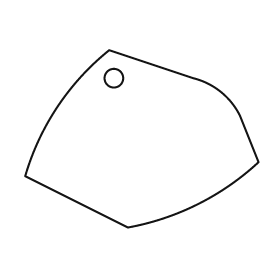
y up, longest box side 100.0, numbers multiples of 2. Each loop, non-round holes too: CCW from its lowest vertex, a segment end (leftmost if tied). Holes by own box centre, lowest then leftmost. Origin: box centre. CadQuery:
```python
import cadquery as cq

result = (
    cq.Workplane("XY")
    .moveTo(-6.0, -38.0)
    .threePointArc((24.0, -28.0), (50.0, -10.0))
    .lineTo(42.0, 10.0)
    .threePointArc((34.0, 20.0), (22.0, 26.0))
    .lineTo(-14.0, 38.0)
    .threePointArc((-36.0, 14.0), (-50.0, -16.0))
    .close()
    .moveTo(-12.0, 26.0)
    .circle(4.0)
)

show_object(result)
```